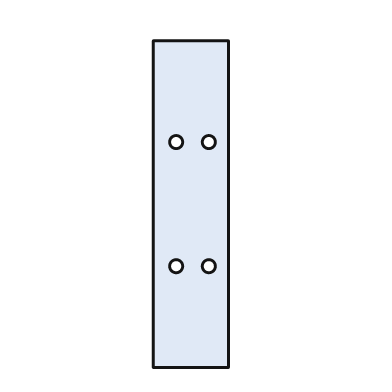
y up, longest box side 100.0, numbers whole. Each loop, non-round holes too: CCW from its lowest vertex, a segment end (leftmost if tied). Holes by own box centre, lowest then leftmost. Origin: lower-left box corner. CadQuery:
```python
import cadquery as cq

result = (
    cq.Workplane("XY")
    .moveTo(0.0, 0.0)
    .lineTo(23.0, 0.0)
    .lineTo(23.0, 100.0)
    .lineTo(0.0, 100.0)
    .close()
    .moveTo(7.0, 31.0)
    .circle(2.0)
    .moveTo(17.0, 31.0)
    .circle(2.0)
    .moveTo(7.0, 69.0)
    .circle(2.0)
    .moveTo(17.0, 69.0)
    .circle(2.0)
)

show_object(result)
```